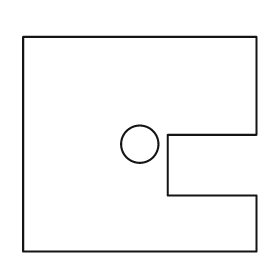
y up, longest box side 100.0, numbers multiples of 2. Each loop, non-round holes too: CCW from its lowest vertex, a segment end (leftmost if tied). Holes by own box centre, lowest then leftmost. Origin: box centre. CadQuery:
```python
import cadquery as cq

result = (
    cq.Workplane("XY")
    .moveTo(-50.0, -46.0)
    .lineTo(50.0, -46.0)
    .lineTo(50.0, -22.0)
    .lineTo(12.0, -22.0)
    .lineTo(12.0, 4.0)
    .lineTo(50.0, 4.0)
    .lineTo(50.0, 46.0)
    .lineTo(-50.0, 46.0)
    .close()
    .moveTo(0.0, 0.0)
    .circle(8.0)
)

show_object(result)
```